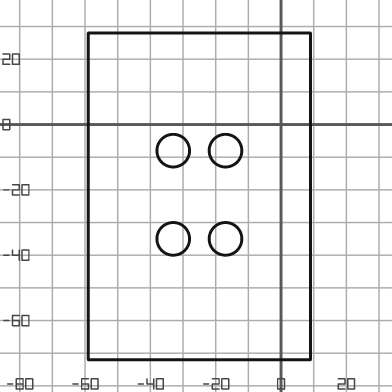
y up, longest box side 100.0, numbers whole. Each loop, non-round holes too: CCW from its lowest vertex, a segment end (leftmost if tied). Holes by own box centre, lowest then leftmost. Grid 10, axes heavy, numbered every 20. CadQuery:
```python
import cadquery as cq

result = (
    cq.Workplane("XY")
    .moveTo(-59.0, -72.0)
    .lineTo(9.0, -72.0)
    .lineTo(9.0, 28.0)
    .lineTo(-59.0, 28.0)
    .close()
    .moveTo(-33.0, -35.0)
    .circle(5.0)
    .moveTo(-17.0, -35.0)
    .circle(5.0)
    .moveTo(-33.0, -8.0)
    .circle(5.0)
    .moveTo(-17.0, -8.0)
    .circle(5.0)
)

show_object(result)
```